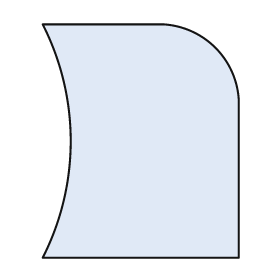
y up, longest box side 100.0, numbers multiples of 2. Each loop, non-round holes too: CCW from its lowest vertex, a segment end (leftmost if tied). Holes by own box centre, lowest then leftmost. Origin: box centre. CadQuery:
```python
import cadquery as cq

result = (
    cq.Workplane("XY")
    .moveTo(-42.0, -50.0)
    .lineTo(42.0, -50.0)
    .lineTo(42.0, 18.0)
    .threePointArc((32.0, 40.0), (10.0, 50.0))
    .lineTo(-42.0, 50.0)
    .threePointArc((-30.0, 0.0), (-42.0, -50.0))
    .close()
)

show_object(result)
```